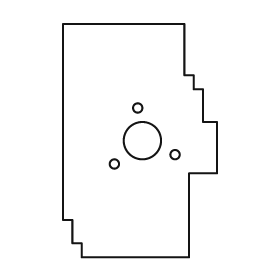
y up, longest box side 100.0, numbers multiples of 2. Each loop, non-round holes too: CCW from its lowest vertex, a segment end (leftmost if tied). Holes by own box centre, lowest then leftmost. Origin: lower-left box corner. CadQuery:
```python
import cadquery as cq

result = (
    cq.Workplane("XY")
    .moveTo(8.0, 0.0)
    .lineTo(54.0, 0.0)
    .lineTo(54.0, 36.0)
    .lineTo(66.0, 36.0)
    .lineTo(66.0, 58.0)
    .lineTo(60.0, 58.0)
    .lineTo(60.0, 72.0)
    .lineTo(56.0, 72.0)
    .lineTo(56.0, 78.0)
    .lineTo(52.0, 78.0)
    .lineTo(52.0, 100.0)
    .lineTo(0.0, 100.0)
    .lineTo(0.0, 16.0)
    .lineTo(4.0, 16.0)
    .lineTo(4.0, 6.0)
    .lineTo(8.0, 6.0)
    .close()
    .moveTo(22.0, 40.0)
    .circle(2.0)
    .moveTo(48.0, 44.0)
    .circle(2.0)
    .moveTo(34.0, 50.0)
    .circle(8.0)
    .moveTo(32.0, 64.0)
    .circle(2.0)
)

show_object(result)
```